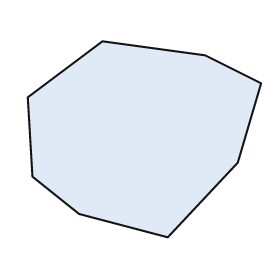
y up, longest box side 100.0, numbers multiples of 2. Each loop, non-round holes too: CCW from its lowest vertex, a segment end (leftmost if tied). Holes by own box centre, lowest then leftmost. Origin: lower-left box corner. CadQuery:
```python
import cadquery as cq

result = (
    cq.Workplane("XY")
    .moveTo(60.0, 0.0)
    .lineTo(90.0, 32.0)
    .lineTo(100.0, 66.0)
    .lineTo(76.0, 78.0)
    .lineTo(32.0, 84.0)
    .lineTo(0.0, 60.0)
    .lineTo(2.0, 26.0)
    .lineTo(22.0, 10.0)
    .close()
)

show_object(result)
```